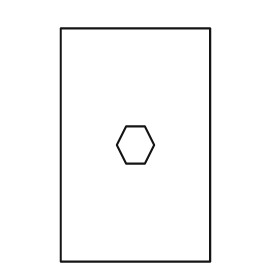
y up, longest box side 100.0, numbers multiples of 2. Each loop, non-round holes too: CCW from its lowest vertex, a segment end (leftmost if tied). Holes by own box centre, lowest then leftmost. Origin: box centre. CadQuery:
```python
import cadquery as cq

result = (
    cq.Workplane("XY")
    .moveTo(-32.0, -50.0)
    .lineTo(32.0, -50.0)
    .lineTo(32.0, 50.0)
    .lineTo(-32.0, 50.0)
    .close()
    .moveTo(-4.0, -8.0)
    .lineTo(4.0, -8.0)
    .lineTo(8.0, 0.0)
    .lineTo(4.0, 8.0)
    .lineTo(-4.0, 8.0)
    .lineTo(-8.0, 0.0)
    .close()
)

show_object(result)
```